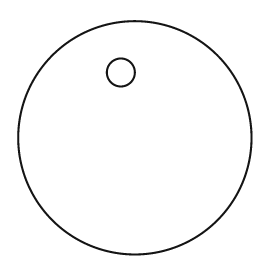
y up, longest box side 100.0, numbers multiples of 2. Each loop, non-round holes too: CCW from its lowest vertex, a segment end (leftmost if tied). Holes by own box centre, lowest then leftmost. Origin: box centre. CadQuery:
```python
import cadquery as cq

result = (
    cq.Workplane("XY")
    .moveTo(0.0, 0.0)
    .circle(50.0)
    .moveTo(-6.0, 28.0)
    .circle(6.0)
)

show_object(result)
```